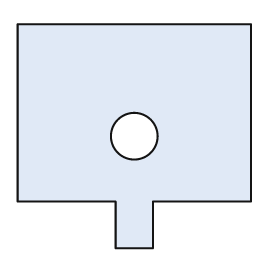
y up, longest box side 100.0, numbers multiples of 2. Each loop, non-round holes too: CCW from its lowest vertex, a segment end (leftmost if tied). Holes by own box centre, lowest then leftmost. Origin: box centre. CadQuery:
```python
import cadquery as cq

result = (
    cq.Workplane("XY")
    .moveTo(-8.0, -48.0)
    .lineTo(8.0, -48.0)
    .lineTo(8.0, -28.0)
    .lineTo(50.0, -28.0)
    .lineTo(50.0, 48.0)
    .lineTo(-50.0, 48.0)
    .lineTo(-50.0, -28.0)
    .lineTo(-8.0, -28.0)
    .close()
    .moveTo(0.0, 0.0)
    .circle(10.0)
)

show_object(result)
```